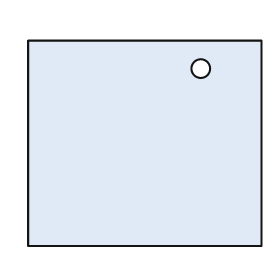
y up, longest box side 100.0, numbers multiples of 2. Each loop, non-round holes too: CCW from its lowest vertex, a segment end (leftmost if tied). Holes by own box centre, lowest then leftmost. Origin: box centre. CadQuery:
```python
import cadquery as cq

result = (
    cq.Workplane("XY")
    .moveTo(-50.0, -44.0)
    .lineTo(50.0, -44.0)
    .lineTo(50.0, 44.0)
    .lineTo(-50.0, 44.0)
    .close()
    .moveTo(24.0, 32.0)
    .circle(4.0)
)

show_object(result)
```